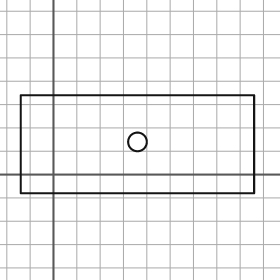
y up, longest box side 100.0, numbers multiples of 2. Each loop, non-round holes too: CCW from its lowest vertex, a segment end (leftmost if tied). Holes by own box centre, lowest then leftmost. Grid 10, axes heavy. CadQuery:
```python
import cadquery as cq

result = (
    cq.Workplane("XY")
    .moveTo(-14.0, -8.0)
    .lineTo(86.0, -8.0)
    .lineTo(86.0, 34.0)
    .lineTo(-14.0, 34.0)
    .close()
    .moveTo(36.0, 14.0)
    .circle(4.0)
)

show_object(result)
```